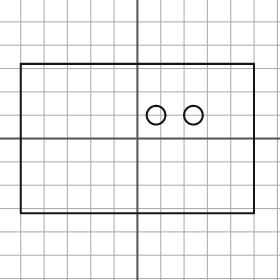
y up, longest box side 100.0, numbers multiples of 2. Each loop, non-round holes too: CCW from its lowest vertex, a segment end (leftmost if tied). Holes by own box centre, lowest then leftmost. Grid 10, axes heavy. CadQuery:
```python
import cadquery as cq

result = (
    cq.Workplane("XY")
    .moveTo(-50.0, -32.0)
    .lineTo(50.0, -32.0)
    .lineTo(50.0, 32.0)
    .lineTo(-50.0, 32.0)
    .close()
    .moveTo(8.0, 10.0)
    .circle(4.0)
    .moveTo(24.0, 10.0)
    .circle(4.0)
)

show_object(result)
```